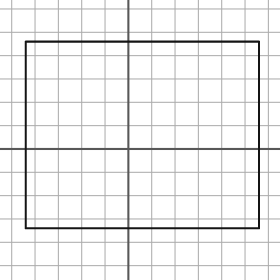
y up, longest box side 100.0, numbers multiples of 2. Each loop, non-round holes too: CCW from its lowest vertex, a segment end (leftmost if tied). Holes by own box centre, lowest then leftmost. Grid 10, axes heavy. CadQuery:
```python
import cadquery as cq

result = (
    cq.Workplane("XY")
    .moveTo(-44.0, -34.0)
    .lineTo(56.0, -34.0)
    .lineTo(56.0, 46.0)
    .lineTo(-44.0, 46.0)
    .close()
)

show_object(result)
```